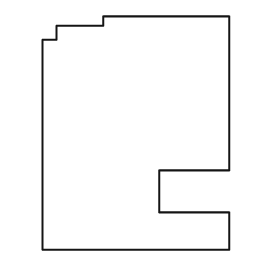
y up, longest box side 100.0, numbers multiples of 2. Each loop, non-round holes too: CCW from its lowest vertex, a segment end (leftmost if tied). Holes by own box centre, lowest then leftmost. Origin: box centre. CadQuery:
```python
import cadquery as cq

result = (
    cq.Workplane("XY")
    .moveTo(-40.0, -50.0)
    .lineTo(40.0, -50.0)
    .lineTo(40.0, -34.0)
    .lineTo(10.0, -34.0)
    .lineTo(10.0, -16.0)
    .lineTo(40.0, -16.0)
    .lineTo(40.0, 50.0)
    .lineTo(-14.0, 50.0)
    .lineTo(-14.0, 46.0)
    .lineTo(-34.0, 46.0)
    .lineTo(-34.0, 40.0)
    .lineTo(-40.0, 40.0)
    .close()
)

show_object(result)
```